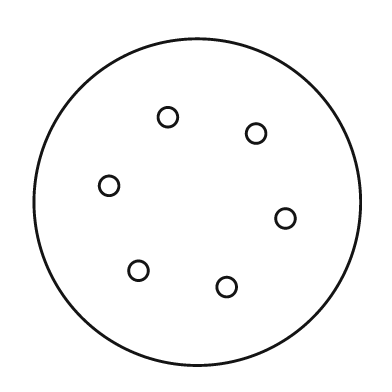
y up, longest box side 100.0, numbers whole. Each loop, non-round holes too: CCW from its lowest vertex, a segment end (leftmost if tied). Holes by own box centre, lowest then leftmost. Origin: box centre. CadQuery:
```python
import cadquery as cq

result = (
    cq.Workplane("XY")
    .moveTo(0.0, 0.0)
    .circle(50.0)
    .moveTo(9.0, -26.0)
    .circle(3.0)
    .moveTo(-18.0, -21.0)
    .circle(3.0)
    .moveTo(27.0, -5.0)
    .circle(3.0)
    .moveTo(-27.0, 5.0)
    .circle(3.0)
    .moveTo(18.0, 21.0)
    .circle(3.0)
    .moveTo(-9.0, 26.0)
    .circle(3.0)
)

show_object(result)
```